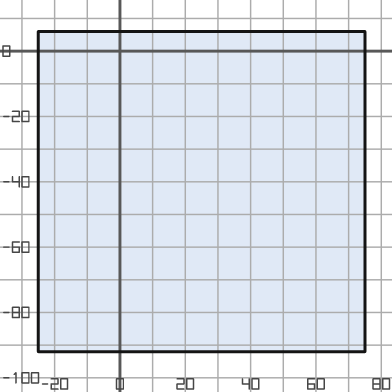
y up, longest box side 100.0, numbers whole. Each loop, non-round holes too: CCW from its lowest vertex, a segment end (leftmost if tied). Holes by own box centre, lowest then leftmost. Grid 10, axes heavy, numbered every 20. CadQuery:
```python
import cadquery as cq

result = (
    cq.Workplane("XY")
    .moveTo(-25.0, -92.0)
    .lineTo(75.0, -92.0)
    .lineTo(75.0, 6.0)
    .lineTo(-25.0, 6.0)
    .close()
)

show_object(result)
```